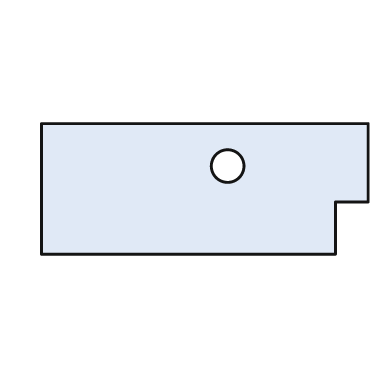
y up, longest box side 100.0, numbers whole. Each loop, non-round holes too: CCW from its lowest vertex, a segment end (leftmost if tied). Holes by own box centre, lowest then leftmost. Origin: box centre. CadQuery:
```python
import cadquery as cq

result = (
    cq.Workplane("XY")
    .moveTo(-50.0, -20.0)
    .lineTo(40.0, -20.0)
    .lineTo(40.0, -4.0)
    .lineTo(50.0, -4.0)
    .lineTo(50.0, 20.0)
    .lineTo(-50.0, 20.0)
    .close()
    .moveTo(7.0, 7.0)
    .circle(5.0)
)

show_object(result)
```